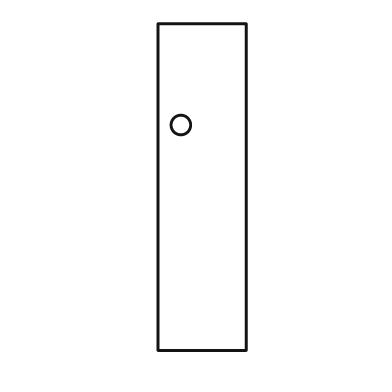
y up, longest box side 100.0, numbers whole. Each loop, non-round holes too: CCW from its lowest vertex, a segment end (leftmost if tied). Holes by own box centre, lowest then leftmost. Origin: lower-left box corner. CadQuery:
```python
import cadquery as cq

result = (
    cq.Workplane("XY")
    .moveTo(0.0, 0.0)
    .lineTo(27.0, 0.0)
    .lineTo(27.0, 100.0)
    .lineTo(0.0, 100.0)
    .close()
    .moveTo(7.0, 69.0)
    .circle(3.0)
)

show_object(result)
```